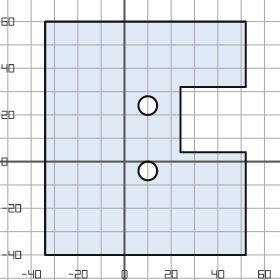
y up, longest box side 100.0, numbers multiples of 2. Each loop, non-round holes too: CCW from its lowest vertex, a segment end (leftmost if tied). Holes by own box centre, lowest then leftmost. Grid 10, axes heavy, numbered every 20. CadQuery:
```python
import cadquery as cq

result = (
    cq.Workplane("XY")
    .moveTo(-34.0, -40.0)
    .lineTo(52.0, -40.0)
    .lineTo(52.0, 4.0)
    .lineTo(24.0, 4.0)
    .lineTo(24.0, 32.0)
    .lineTo(52.0, 32.0)
    .lineTo(52.0, 60.0)
    .lineTo(-34.0, 60.0)
    .close()
    .moveTo(10.0, -4.0)
    .circle(4.0)
    .moveTo(10.0, 24.0)
    .circle(4.0)
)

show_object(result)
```